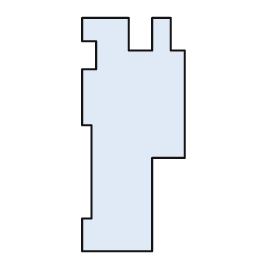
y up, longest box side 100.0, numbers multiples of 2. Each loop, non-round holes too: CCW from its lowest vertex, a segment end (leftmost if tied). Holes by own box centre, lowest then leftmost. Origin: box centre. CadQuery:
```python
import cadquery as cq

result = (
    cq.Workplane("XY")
    .moveTo(-22.0, -50.0)
    .lineTo(8.0, -50.0)
    .lineTo(8.0, -10.0)
    .lineTo(22.0, -10.0)
    .lineTo(22.0, 36.0)
    .lineTo(16.0, 36.0)
    .lineTo(16.0, 50.0)
    .lineTo(8.0, 50.0)
    .lineTo(8.0, 36.0)
    .lineTo(-2.0, 36.0)
    .lineTo(-2.0, 50.0)
    .lineTo(-22.0, 50.0)
    .lineTo(-22.0, 40.0)
    .lineTo(-16.0, 40.0)
    .lineTo(-16.0, 28.0)
    .lineTo(-22.0, 28.0)
    .lineTo(-22.0, 4.0)
    .lineTo(-18.0, 4.0)
    .lineTo(-18.0, -36.0)
    .lineTo(-22.0, -36.0)
    .close()
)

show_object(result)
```